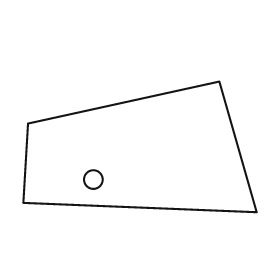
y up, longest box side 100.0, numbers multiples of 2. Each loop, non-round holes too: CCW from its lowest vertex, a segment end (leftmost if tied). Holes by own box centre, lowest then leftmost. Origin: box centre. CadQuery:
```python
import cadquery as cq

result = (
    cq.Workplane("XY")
    .moveTo(50.0, -28.0)
    .lineTo(34.0, 28.0)
    .lineTo(-48.0, 10.0)
    .lineTo(-50.0, -24.0)
    .close()
    .moveTo(-20.0, -14.0)
    .circle(4.0)
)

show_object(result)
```